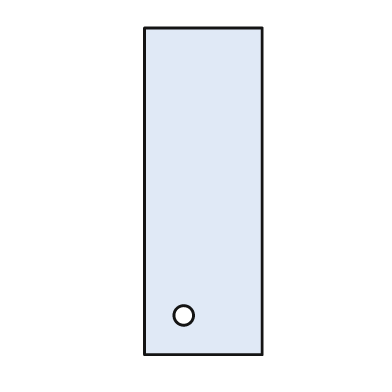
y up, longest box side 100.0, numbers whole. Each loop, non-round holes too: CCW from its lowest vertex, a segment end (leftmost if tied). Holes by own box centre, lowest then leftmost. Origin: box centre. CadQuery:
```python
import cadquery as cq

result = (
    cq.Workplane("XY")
    .moveTo(-18.0, -50.0)
    .lineTo(18.0, -50.0)
    .lineTo(18.0, 50.0)
    .lineTo(-18.0, 50.0)
    .close()
    .moveTo(-6.0, -38.0)
    .circle(3.0)
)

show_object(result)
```